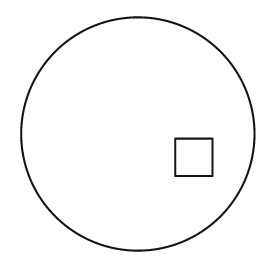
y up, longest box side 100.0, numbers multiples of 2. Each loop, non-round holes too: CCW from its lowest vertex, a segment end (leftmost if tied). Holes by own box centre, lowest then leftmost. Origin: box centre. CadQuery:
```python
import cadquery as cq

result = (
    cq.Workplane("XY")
    .moveTo(0.0, 0.0)
    .circle(50.0)
    .moveTo(16.0, -18.0)
    .lineTo(32.0, -18.0)
    .lineTo(32.0, -2.0)
    .lineTo(16.0, -2.0)
    .close()
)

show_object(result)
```